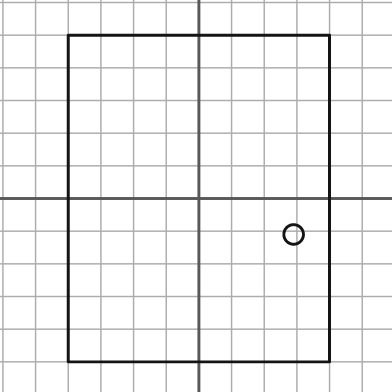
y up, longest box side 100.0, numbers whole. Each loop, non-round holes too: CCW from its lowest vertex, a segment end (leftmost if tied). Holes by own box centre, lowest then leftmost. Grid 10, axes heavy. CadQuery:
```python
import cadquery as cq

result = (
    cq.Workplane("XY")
    .moveTo(-40.0, -50.0)
    .lineTo(40.0, -50.0)
    .lineTo(40.0, 50.0)
    .lineTo(-40.0, 50.0)
    .close()
    .moveTo(29.0, -11.0)
    .circle(3.0)
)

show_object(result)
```